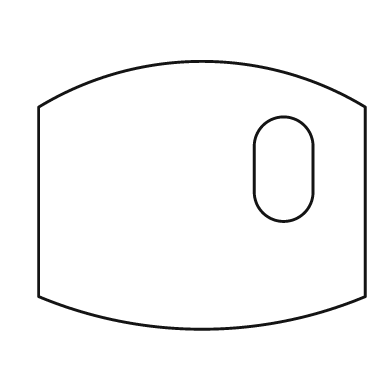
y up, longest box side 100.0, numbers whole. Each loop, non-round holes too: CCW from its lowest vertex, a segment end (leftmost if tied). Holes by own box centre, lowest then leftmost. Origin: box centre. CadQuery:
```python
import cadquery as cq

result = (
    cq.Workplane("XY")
    .moveTo(-50.0, -31.0)
    .threePointArc((0.0, -41.0), (50.0, -31.0))
    .lineTo(50.0, 27.0)
    .threePointArc((0.0, 41.0), (-50.0, 27.0))
    .close()
    .moveTo(16.0, 1.0)
    .threePointArc((25.0, -8.0), (34.0, 1.0))
    .lineTo(34.0, 15.0)
    .threePointArc((25.0, 24.0), (16.0, 15.0))
    .close()
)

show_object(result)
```